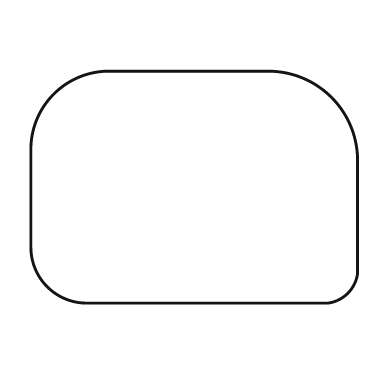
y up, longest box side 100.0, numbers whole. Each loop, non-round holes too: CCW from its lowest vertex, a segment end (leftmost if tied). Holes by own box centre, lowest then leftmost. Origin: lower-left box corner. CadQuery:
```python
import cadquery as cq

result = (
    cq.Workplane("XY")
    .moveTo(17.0, 0.0)
    .lineTo(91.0, 0.0)
    .threePointArc((97.0, 3.0), (100.0, 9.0))
    .lineTo(100.0, 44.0)
    .threePointArc((92.0, 63.0), (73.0, 71.0))
    .lineTo(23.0, 71.0)
    .threePointArc((7.0, 64.0), (0.0, 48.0))
    .lineTo(0.0, 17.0)
    .threePointArc((5.0, 5.0), (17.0, 0.0))
    .close()
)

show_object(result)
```